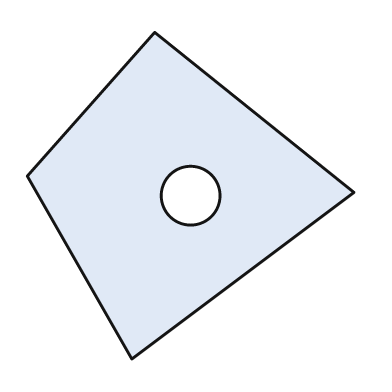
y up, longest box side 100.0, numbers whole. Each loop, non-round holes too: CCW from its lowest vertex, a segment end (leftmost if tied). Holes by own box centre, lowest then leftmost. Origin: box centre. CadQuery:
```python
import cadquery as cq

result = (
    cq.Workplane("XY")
    .moveTo(-18.0, -50.0)
    .lineTo(50.0, 1.0)
    .lineTo(-11.0, 50.0)
    .lineTo(-50.0, 6.0)
    .close()
    .moveTo(0.0, 0.0)
    .circle(9.0)
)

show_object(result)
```